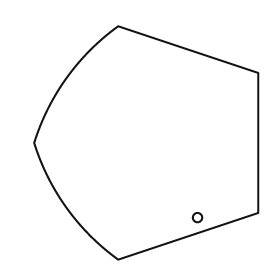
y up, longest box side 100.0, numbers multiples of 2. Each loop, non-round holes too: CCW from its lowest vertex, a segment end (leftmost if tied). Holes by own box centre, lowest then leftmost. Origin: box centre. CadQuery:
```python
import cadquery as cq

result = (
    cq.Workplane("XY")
    .moveTo(-12.0, -50.0)
    .lineTo(48.0, -30.0)
    .lineTo(48.0, 30.0)
    .lineTo(-12.0, 50.0)
    .threePointArc((-34.0, 28.0), (-48.0, 0.0))
    .threePointArc((-34.0, -28.0), (-12.0, -50.0))
    .close()
    .moveTo(22.0, -32.0)
    .circle(2.0)
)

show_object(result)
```